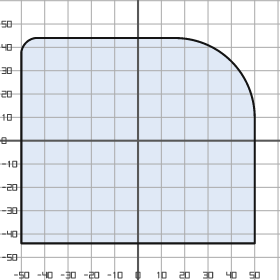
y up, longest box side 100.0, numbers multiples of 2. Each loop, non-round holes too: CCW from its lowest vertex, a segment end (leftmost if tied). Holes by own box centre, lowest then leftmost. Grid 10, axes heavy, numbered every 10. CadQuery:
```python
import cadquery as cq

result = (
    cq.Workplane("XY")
    .moveTo(-50.0, -44.0)
    .lineTo(50.0, -44.0)
    .lineTo(50.0, 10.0)
    .threePointArc((40.0, 34.0), (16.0, 44.0))
    .lineTo(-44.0, 44.0)
    .threePointArc((-48.0, 42.0), (-50.0, 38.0))
    .close()
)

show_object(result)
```